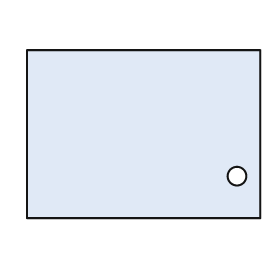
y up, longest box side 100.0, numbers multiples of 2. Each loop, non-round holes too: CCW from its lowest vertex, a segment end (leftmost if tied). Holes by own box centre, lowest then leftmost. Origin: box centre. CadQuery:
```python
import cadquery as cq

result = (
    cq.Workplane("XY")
    .moveTo(-50.0, -36.0)
    .lineTo(50.0, -36.0)
    .lineTo(50.0, 36.0)
    .lineTo(-50.0, 36.0)
    .close()
    .moveTo(40.0, -18.0)
    .circle(4.0)
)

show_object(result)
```